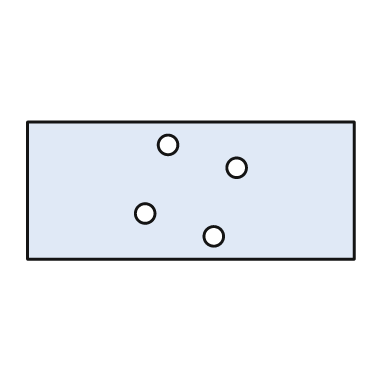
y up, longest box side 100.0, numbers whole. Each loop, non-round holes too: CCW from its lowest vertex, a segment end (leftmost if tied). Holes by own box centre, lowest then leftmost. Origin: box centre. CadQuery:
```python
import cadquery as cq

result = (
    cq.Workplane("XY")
    .moveTo(-50.0, -21.0)
    .lineTo(50.0, -21.0)
    .lineTo(50.0, 21.0)
    .lineTo(-50.0, 21.0)
    .close()
    .moveTo(7.0, -14.0)
    .circle(3.0)
    .moveTo(-14.0, -7.0)
    .circle(3.0)
    .moveTo(14.0, 7.0)
    .circle(3.0)
    .moveTo(-7.0, 14.0)
    .circle(3.0)
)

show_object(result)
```